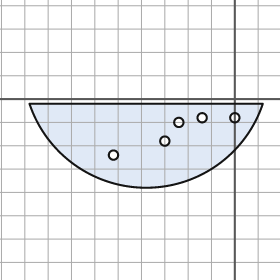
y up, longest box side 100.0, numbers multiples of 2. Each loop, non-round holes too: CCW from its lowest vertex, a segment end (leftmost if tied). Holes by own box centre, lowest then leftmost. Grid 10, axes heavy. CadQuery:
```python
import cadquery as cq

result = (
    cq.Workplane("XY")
    .moveTo(-88.0, -2.0)
    .threePointArc((-38.0, -38.0), (12.0, -2.0))
    .close()
    .moveTo(-52.0, -24.0)
    .circle(2.0)
    .moveTo(-30.0, -18.0)
    .circle(2.0)
    .moveTo(-24.0, -10.0)
    .circle(2.0)
    .moveTo(-14.0, -8.0)
    .circle(2.0)
    .moveTo(0.0, -8.0)
    .circle(2.0)
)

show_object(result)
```